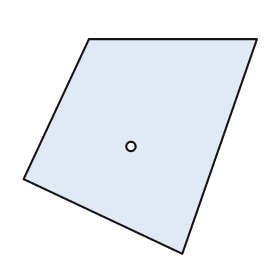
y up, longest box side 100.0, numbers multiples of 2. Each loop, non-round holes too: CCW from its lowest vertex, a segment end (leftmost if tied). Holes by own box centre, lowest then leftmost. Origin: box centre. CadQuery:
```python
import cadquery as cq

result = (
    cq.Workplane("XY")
    .moveTo(18.0, -46.0)
    .lineTo(50.0, 46.0)
    .lineTo(-22.0, 46.0)
    .lineTo(-50.0, -14.0)
    .close()
    .moveTo(-4.0, 0.0)
    .circle(2.0)
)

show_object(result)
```